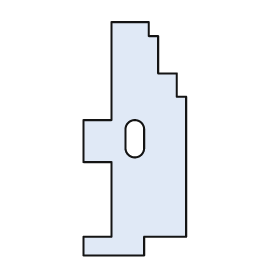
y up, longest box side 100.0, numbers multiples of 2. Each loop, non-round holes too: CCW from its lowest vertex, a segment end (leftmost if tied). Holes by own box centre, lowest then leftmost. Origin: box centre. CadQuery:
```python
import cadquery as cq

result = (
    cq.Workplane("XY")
    .moveTo(-22.0, -50.0)
    .lineTo(4.0, -50.0)
    .lineTo(4.0, -42.0)
    .lineTo(22.0, -42.0)
    .lineTo(22.0, 18.0)
    .lineTo(18.0, 18.0)
    .lineTo(18.0, 28.0)
    .lineTo(10.0, 28.0)
    .lineTo(10.0, 44.0)
    .lineTo(6.0, 44.0)
    .lineTo(6.0, 50.0)
    .lineTo(-10.0, 50.0)
    .lineTo(-10.0, 8.0)
    .lineTo(-22.0, 8.0)
    .lineTo(-22.0, -10.0)
    .lineTo(-10.0, -10.0)
    .lineTo(-10.0, -42.0)
    .lineTo(-22.0, -42.0)
    .close()
    .moveTo(-4.0, -4.0)
    .threePointArc((0.0, -8.0), (4.0, -4.0))
    .lineTo(4.0, 4.0)
    .threePointArc((0.0, 8.0), (-4.0, 4.0))
    .close()
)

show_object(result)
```